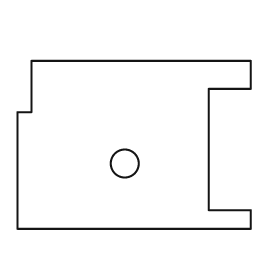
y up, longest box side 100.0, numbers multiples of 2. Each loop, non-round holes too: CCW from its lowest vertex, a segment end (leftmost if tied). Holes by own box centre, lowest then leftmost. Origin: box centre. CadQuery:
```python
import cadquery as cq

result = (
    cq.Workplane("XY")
    .moveTo(-50.0, -36.0)
    .lineTo(50.0, -36.0)
    .lineTo(50.0, -28.0)
    .lineTo(32.0, -28.0)
    .lineTo(32.0, 24.0)
    .lineTo(50.0, 24.0)
    .lineTo(50.0, 36.0)
    .lineTo(-44.0, 36.0)
    .lineTo(-44.0, 14.0)
    .lineTo(-50.0, 14.0)
    .close()
    .moveTo(-4.0, -8.0)
    .circle(6.0)
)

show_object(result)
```